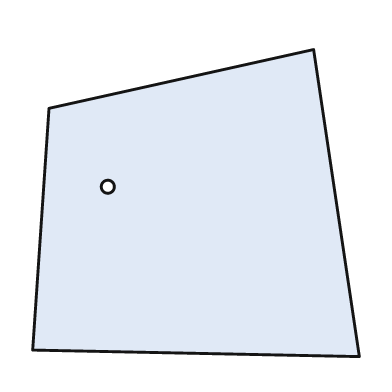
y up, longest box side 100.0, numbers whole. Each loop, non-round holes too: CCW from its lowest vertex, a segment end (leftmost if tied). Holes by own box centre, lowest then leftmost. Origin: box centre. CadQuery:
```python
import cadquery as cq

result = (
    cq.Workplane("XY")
    .moveTo(50.0, -47.0)
    .lineTo(36.0, 47.0)
    .lineTo(-45.0, 29.0)
    .lineTo(-50.0, -45.0)
    .close()
    .moveTo(-27.0, 5.0)
    .circle(2.0)
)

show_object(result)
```